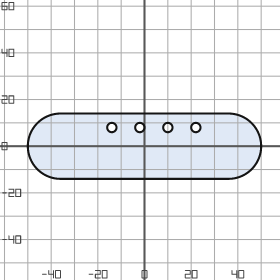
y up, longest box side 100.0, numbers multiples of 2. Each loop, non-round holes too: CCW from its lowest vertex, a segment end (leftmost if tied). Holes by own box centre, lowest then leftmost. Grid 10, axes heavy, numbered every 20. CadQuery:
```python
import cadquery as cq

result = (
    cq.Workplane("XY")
    .moveTo(-36.0, -14.0)
    .lineTo(36.0, -14.0)
    .threePointArc((50.0, 0.0), (36.0, 14.0))
    .lineTo(-36.0, 14.0)
    .threePointArc((-50.0, 0.0), (-36.0, -14.0))
    .close()
    .moveTo(-14.0, 8.0)
    .circle(2.0)
    .moveTo(-2.0, 8.0)
    .circle(2.0)
    .moveTo(10.0, 8.0)
    .circle(2.0)
    .moveTo(22.0, 8.0)
    .circle(2.0)
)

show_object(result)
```